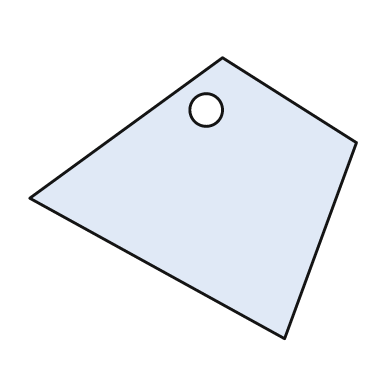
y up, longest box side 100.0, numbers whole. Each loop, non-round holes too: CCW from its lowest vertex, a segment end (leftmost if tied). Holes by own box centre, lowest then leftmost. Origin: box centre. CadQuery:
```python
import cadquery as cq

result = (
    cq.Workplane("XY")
    .moveTo(28.0, -43.0)
    .lineTo(50.0, 17.0)
    .lineTo(9.0, 43.0)
    .lineTo(-50.0, 0.0)
    .close()
    .moveTo(4.0, 27.0)
    .circle(5.0)
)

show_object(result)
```